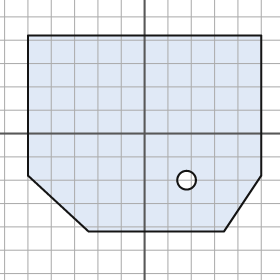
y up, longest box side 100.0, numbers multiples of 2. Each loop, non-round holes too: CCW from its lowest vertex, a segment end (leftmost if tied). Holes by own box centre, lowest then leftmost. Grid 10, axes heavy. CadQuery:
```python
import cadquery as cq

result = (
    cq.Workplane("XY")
    .moveTo(-24.0, -42.0)
    .lineTo(34.0, -42.0)
    .lineTo(50.0, -18.0)
    .lineTo(50.0, 42.0)
    .lineTo(-50.0, 42.0)
    .lineTo(-50.0, -18.0)
    .close()
    .moveTo(18.0, -20.0)
    .circle(4.0)
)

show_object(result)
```